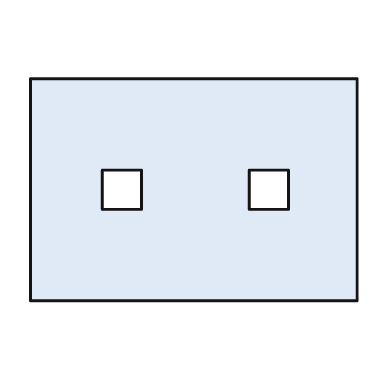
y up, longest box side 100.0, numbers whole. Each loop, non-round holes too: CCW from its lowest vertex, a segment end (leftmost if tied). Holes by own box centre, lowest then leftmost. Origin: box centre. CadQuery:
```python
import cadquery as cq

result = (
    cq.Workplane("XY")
    .moveTo(-50.0, -34.0)
    .lineTo(50.0, -34.0)
    .lineTo(50.0, 34.0)
    .lineTo(-50.0, 34.0)
    .close()
    .moveTo(-28.0, -6.0)
    .lineTo(-16.0, -6.0)
    .lineTo(-16.0, 6.0)
    .lineTo(-28.0, 6.0)
    .close()
    .moveTo(17.0, -6.0)
    .lineTo(29.0, -6.0)
    .lineTo(29.0, 6.0)
    .lineTo(17.0, 6.0)
    .close()
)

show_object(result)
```